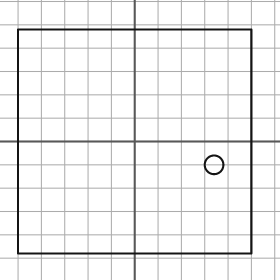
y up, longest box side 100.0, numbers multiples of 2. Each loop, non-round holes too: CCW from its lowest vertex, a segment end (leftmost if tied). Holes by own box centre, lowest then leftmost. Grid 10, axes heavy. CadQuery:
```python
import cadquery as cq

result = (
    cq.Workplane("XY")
    .moveTo(-50.0, -48.0)
    .lineTo(50.0, -48.0)
    .lineTo(50.0, 48.0)
    .lineTo(-50.0, 48.0)
    .close()
    .moveTo(34.0, -10.0)
    .circle(4.0)
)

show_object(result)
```